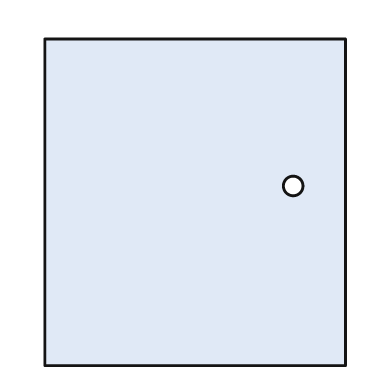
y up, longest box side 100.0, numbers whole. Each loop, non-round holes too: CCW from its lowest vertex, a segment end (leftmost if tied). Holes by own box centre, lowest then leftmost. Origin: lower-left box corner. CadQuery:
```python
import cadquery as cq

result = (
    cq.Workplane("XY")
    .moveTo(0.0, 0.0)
    .lineTo(92.0, 0.0)
    .lineTo(92.0, 100.0)
    .lineTo(0.0, 100.0)
    .close()
    .moveTo(76.0, 55.0)
    .circle(3.0)
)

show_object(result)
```